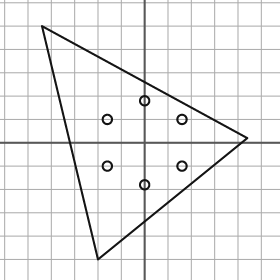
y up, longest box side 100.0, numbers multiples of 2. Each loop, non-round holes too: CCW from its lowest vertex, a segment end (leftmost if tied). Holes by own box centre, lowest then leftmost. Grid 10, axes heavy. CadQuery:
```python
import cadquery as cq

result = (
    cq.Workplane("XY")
    .moveTo(-20.0, -50.0)
    .lineTo(44.0, 2.0)
    .lineTo(-44.0, 50.0)
    .close()
    .moveTo(0.0, -18.0)
    .circle(2.0)
    .moveTo(-16.0, -10.0)
    .circle(2.0)
    .moveTo(16.0, -10.0)
    .circle(2.0)
    .moveTo(-16.0, 10.0)
    .circle(2.0)
    .moveTo(16.0, 10.0)
    .circle(2.0)
    .moveTo(0.0, 18.0)
    .circle(2.0)
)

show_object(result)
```